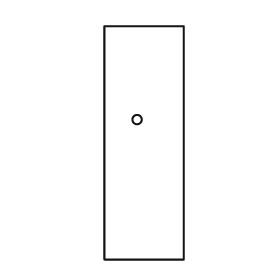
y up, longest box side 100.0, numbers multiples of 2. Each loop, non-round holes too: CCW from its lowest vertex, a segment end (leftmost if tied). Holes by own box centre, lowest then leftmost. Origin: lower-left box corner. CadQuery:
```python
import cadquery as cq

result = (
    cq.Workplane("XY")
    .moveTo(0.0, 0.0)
    .lineTo(34.0, 0.0)
    .lineTo(34.0, 100.0)
    .lineTo(0.0, 100.0)
    .close()
    .moveTo(14.0, 60.0)
    .circle(2.0)
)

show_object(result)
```